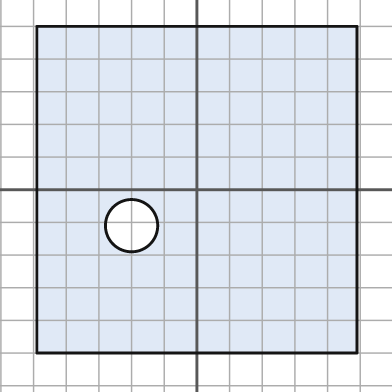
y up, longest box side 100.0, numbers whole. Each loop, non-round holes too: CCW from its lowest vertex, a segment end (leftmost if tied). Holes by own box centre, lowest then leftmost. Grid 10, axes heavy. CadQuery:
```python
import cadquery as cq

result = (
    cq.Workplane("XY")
    .moveTo(-49.0, -50.0)
    .lineTo(49.0, -50.0)
    .lineTo(49.0, 50.0)
    .lineTo(-49.0, 50.0)
    .close()
    .moveTo(-20.0, -11.0)
    .circle(8.0)
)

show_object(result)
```